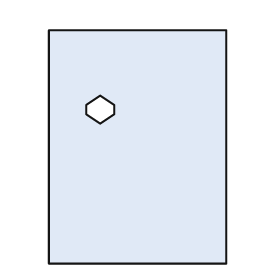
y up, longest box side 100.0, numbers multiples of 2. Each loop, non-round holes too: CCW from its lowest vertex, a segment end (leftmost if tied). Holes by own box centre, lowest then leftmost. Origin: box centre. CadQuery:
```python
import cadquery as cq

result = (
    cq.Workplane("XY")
    .moveTo(-38.0, -50.0)
    .lineTo(38.0, -50.0)
    .lineTo(38.0, 50.0)
    .lineTo(-38.0, 50.0)
    .close()
    .moveTo(-16.0, 10.0)
    .lineTo(-10.0, 14.0)
    .lineTo(-10.0, 18.0)
    .lineTo(-16.0, 22.0)
    .lineTo(-22.0, 18.0)
    .lineTo(-22.0, 14.0)
    .close()
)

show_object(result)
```